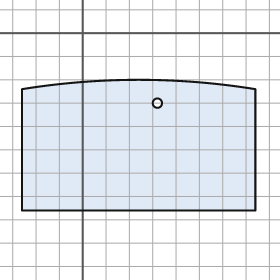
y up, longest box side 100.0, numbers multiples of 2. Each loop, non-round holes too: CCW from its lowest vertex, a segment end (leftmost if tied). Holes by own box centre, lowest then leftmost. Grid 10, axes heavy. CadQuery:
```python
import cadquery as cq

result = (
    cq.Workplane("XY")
    .moveTo(-26.0, -76.0)
    .lineTo(74.0, -76.0)
    .lineTo(74.0, -24.0)
    .threePointArc((24.0, -20.0), (-26.0, -24.0))
    .close()
    .moveTo(32.0, -30.0)
    .circle(2.0)
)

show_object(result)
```